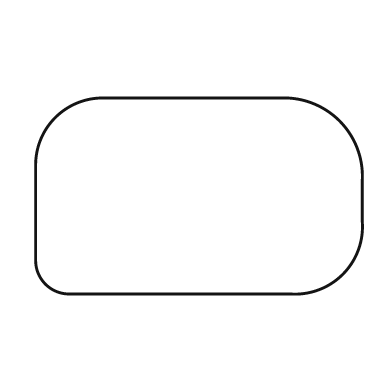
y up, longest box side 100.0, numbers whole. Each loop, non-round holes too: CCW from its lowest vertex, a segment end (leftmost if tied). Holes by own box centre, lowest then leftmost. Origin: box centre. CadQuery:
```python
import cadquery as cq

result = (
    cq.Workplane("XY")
    .moveTo(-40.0, -30.0)
    .lineTo(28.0, -30.0)
    .threePointArc((44.0, -24.0), (50.0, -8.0))
    .lineTo(50.0, 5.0)
    .threePointArc((43.0, 23.0), (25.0, 30.0))
    .lineTo(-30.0, 30.0)
    .threePointArc((-44.0, 24.0), (-50.0, 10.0))
    .lineTo(-50.0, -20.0)
    .threePointArc((-47.0, -27.0), (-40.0, -30.0))
    .close()
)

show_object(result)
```